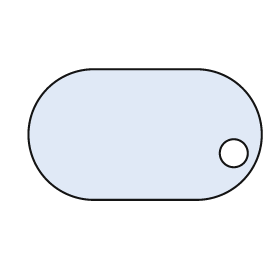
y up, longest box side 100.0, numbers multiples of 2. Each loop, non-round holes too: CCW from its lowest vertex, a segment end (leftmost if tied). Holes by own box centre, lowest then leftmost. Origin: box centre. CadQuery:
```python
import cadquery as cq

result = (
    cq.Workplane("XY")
    .moveTo(-22.0, -28.0)
    .lineTo(22.0, -28.0)
    .threePointArc((50.0, 0.0), (22.0, 28.0))
    .lineTo(-22.0, 28.0)
    .threePointArc((-50.0, 0.0), (-22.0, -28.0))
    .close()
    .moveTo(38.0, -8.0)
    .circle(6.0)
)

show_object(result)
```